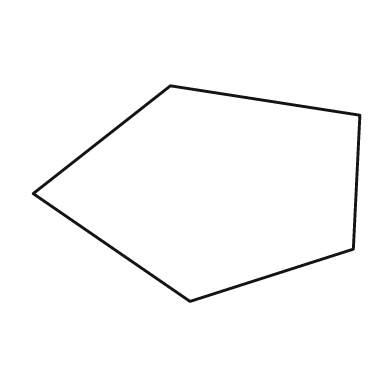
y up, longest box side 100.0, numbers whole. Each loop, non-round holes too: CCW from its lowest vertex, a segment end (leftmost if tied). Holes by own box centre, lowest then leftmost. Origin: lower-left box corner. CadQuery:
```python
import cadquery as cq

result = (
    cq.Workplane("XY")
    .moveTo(48.0, 0.0)
    .lineTo(98.0, 16.0)
    .lineTo(100.0, 57.0)
    .lineTo(42.0, 66.0)
    .lineTo(0.0, 33.0)
    .close()
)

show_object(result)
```